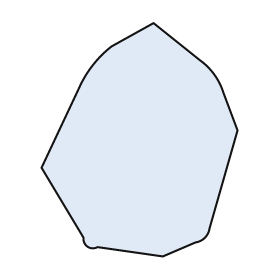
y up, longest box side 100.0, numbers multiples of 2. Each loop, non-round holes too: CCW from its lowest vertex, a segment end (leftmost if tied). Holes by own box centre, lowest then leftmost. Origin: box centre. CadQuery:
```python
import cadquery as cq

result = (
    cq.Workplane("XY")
    .moveTo(10.0, -50.0)
    .lineTo(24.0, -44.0)
    .threePointArc((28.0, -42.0), (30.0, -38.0))
    .lineTo(42.0, 4.0)
    .lineTo(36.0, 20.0)
    .threePointArc((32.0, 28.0), (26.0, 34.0))
    .lineTo(6.0, 50.0)
    .lineTo(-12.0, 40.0)
    .threePointArc((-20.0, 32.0), (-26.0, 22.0))
    .lineTo(-42.0, -12.0)
    .lineTo(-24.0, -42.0)
    .threePointArc((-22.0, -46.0), (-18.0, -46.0))
    .close()
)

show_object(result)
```